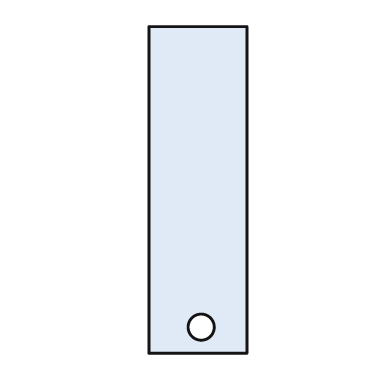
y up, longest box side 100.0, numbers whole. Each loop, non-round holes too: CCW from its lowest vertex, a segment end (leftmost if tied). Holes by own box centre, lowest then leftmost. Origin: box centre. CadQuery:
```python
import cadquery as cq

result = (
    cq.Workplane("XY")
    .moveTo(-15.0, -50.0)
    .lineTo(15.0, -50.0)
    .lineTo(15.0, 50.0)
    .lineTo(-15.0, 50.0)
    .close()
    .moveTo(1.0, -42.0)
    .circle(4.0)
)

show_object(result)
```